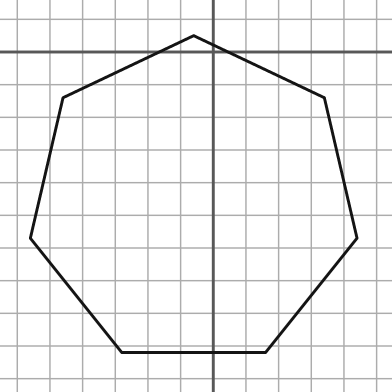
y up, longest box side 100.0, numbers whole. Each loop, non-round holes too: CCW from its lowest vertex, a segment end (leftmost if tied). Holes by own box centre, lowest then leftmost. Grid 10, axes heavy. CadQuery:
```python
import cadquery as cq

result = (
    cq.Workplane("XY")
    .moveTo(-28.0, -92.0)
    .lineTo(16.0, -92.0)
    .lineTo(44.0, -57.0)
    .lineTo(34.0, -14.0)
    .lineTo(-6.0, 5.0)
    .lineTo(-46.0, -14.0)
    .lineTo(-56.0, -57.0)
    .close()
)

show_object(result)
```